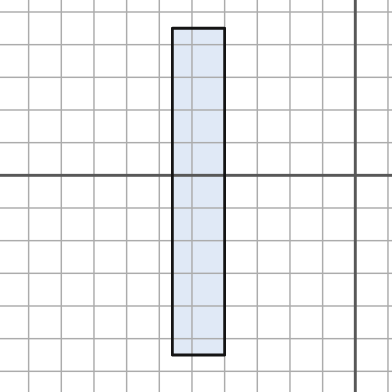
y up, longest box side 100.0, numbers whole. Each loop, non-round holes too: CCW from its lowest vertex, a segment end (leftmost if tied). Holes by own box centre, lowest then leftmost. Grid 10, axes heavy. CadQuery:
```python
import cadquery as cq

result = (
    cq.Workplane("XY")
    .moveTo(-56.0, -55.0)
    .lineTo(-40.0, -55.0)
    .lineTo(-40.0, 45.0)
    .lineTo(-56.0, 45.0)
    .close()
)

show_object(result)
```